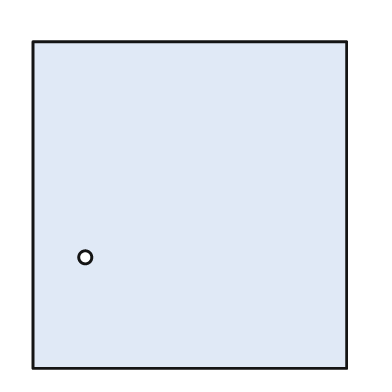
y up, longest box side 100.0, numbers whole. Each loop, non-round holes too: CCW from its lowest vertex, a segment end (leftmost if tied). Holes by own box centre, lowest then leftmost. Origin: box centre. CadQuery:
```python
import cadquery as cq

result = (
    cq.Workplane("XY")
    .moveTo(-48.0, -50.0)
    .lineTo(48.0, -50.0)
    .lineTo(48.0, 50.0)
    .lineTo(-48.0, 50.0)
    .close()
    .moveTo(-32.0, -16.0)
    .circle(2.0)
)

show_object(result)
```